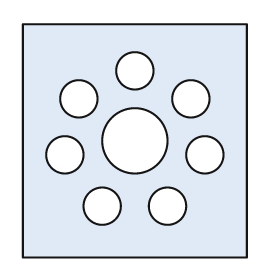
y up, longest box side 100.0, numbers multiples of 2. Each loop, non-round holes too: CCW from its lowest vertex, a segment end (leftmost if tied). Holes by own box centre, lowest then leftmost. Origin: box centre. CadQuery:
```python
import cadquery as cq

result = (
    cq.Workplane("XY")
    .moveTo(-48.0, -50.0)
    .lineTo(48.0, -50.0)
    .lineTo(48.0, 50.0)
    .lineTo(-48.0, 50.0)
    .close()
    .moveTo(-14.0, -28.0)
    .circle(8.0)
    .moveTo(14.0, -28.0)
    .circle(8.0)
    .moveTo(-30.0, -6.0)
    .circle(8.0)
    .moveTo(30.0, -6.0)
    .circle(8.0)
    .moveTo(0.0, 0.0)
    .circle(14.0)
    .moveTo(-24.0, 18.0)
    .circle(8.0)
    .moveTo(24.0, 18.0)
    .circle(8.0)
    .moveTo(0.0, 30.0)
    .circle(8.0)
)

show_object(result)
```